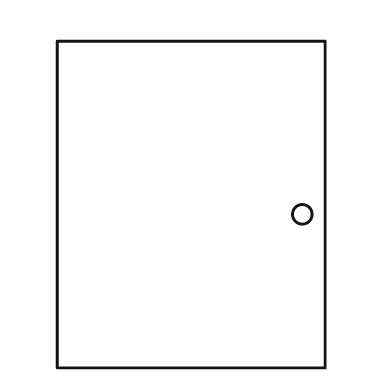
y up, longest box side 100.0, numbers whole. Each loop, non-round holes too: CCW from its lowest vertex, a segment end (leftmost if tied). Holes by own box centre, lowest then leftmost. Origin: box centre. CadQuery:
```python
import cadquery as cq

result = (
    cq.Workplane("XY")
    .moveTo(-41.0, -50.0)
    .lineTo(41.0, -50.0)
    .lineTo(41.0, 50.0)
    .lineTo(-41.0, 50.0)
    .close()
    .moveTo(34.0, -3.0)
    .circle(3.0)
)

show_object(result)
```